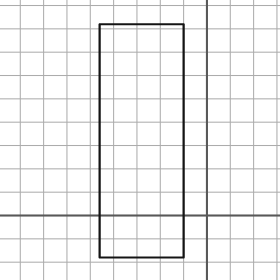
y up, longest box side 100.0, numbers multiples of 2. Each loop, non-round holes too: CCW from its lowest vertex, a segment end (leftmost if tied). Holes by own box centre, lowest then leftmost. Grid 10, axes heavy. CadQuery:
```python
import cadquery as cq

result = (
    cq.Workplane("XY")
    .moveTo(-46.0, -18.0)
    .lineTo(-10.0, -18.0)
    .lineTo(-10.0, 82.0)
    .lineTo(-46.0, 82.0)
    .close()
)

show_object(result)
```